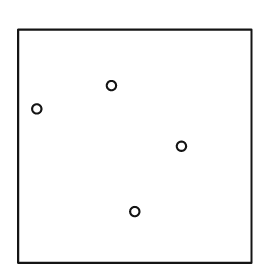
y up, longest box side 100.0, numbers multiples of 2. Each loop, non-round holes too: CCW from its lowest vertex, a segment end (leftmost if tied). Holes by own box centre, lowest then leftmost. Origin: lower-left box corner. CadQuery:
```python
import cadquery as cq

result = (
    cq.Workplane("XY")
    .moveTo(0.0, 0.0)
    .lineTo(100.0, 0.0)
    .lineTo(100.0, 100.0)
    .lineTo(0.0, 100.0)
    .close()
    .moveTo(50.0, 22.0)
    .circle(2.0)
    .moveTo(70.0, 50.0)
    .circle(2.0)
    .moveTo(8.0, 66.0)
    .circle(2.0)
    .moveTo(40.0, 76.0)
    .circle(2.0)
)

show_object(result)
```